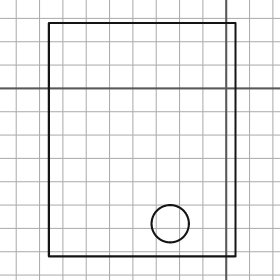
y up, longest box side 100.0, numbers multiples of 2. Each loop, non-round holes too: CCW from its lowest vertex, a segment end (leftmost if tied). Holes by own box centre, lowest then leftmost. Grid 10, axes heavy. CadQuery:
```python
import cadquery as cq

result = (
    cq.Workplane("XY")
    .moveTo(-76.0, -72.0)
    .lineTo(4.0, -72.0)
    .lineTo(4.0, 28.0)
    .lineTo(-76.0, 28.0)
    .close()
    .moveTo(-24.0, -58.0)
    .circle(8.0)
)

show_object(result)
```